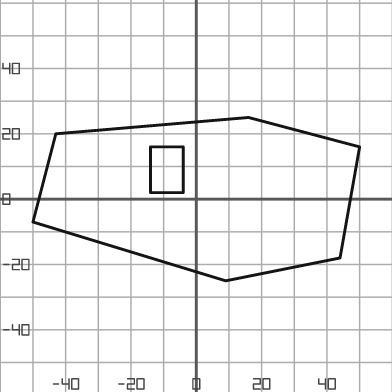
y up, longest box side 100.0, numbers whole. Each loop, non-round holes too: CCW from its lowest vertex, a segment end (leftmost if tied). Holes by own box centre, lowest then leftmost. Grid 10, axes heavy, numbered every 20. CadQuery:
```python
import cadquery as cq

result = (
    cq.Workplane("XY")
    .moveTo(9.0, -25.0)
    .lineTo(44.0, -18.0)
    .lineTo(50.0, 16.0)
    .lineTo(16.0, 25.0)
    .lineTo(-43.0, 20.0)
    .lineTo(-50.0, -7.0)
    .close()
    .moveTo(-14.0, 2.0)
    .lineTo(-4.0, 2.0)
    .lineTo(-4.0, 16.0)
    .lineTo(-14.0, 16.0)
    .close()
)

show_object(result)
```